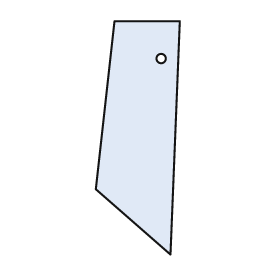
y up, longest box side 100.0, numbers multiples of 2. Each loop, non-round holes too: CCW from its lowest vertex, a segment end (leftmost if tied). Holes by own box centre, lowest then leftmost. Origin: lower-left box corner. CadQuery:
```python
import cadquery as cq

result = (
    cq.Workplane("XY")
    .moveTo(32.0, 0.0)
    .lineTo(36.0, 100.0)
    .lineTo(8.0, 100.0)
    .lineTo(0.0, 28.0)
    .close()
    .moveTo(28.0, 84.0)
    .circle(2.0)
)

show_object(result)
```